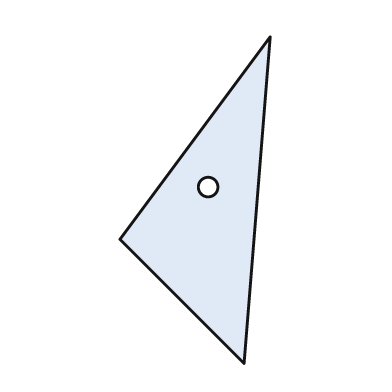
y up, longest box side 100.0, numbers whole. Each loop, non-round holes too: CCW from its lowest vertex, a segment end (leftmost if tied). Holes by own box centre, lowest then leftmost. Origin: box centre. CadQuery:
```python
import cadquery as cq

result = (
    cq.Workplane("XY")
    .moveTo(15.0, -50.0)
    .lineTo(23.0, 50.0)
    .lineTo(-23.0, -12.0)
    .close()
    .moveTo(4.0, 4.0)
    .circle(3.0)
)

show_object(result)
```